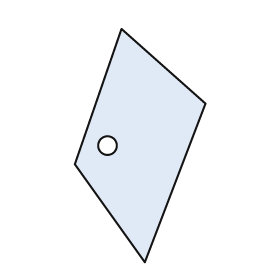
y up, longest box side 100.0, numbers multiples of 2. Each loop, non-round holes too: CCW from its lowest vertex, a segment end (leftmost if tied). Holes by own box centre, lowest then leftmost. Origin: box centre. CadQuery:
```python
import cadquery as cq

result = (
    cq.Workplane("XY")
    .moveTo(2.0, -50.0)
    .lineTo(28.0, 18.0)
    .lineTo(-8.0, 50.0)
    .lineTo(-28.0, -8.0)
    .close()
    .moveTo(-14.0, 0.0)
    .circle(4.0)
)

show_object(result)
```